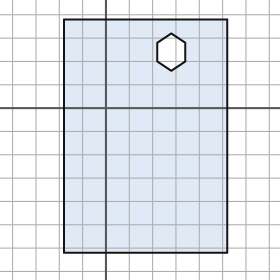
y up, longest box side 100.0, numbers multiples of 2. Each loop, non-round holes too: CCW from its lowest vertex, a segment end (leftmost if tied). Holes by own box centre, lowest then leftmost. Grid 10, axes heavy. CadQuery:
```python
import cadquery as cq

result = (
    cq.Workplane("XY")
    .moveTo(-18.0, -62.0)
    .lineTo(52.0, -62.0)
    .lineTo(52.0, 38.0)
    .lineTo(-18.0, 38.0)
    .close()
    .moveTo(28.0, 16.0)
    .lineTo(34.0, 20.0)
    .lineTo(34.0, 28.0)
    .lineTo(28.0, 32.0)
    .lineTo(22.0, 28.0)
    .lineTo(22.0, 20.0)
    .close()
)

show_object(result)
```